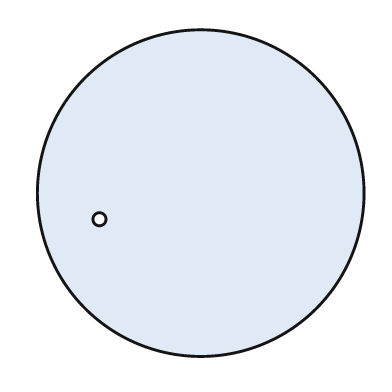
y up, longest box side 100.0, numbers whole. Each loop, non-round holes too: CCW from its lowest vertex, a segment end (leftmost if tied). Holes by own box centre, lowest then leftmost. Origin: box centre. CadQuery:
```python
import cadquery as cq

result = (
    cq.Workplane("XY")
    .moveTo(0.0, 0.0)
    .circle(50.0)
    .moveTo(-31.0, -8.0)
    .circle(2.0)
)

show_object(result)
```